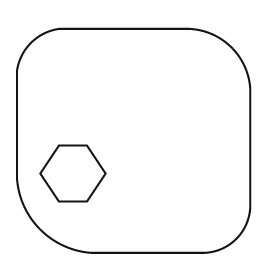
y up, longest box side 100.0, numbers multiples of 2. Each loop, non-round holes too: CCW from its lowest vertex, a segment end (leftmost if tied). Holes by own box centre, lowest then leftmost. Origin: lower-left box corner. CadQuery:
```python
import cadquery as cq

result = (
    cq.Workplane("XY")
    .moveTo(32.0, 0.0)
    .lineTo(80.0, 0.0)
    .threePointArc((94.0, 6.0), (100.0, 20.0))
    .lineTo(100.0, 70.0)
    .threePointArc((92.0, 88.0), (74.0, 96.0))
    .lineTo(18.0, 96.0)
    .threePointArc((6.0, 90.0), (0.0, 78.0))
    .lineTo(0.0, 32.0)
    .threePointArc((10.0, 10.0), (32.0, 0.0))
    .close()
    .moveTo(18.0, 22.0)
    .lineTo(30.0, 22.0)
    .lineTo(38.0, 34.0)
    .lineTo(30.0, 46.0)
    .lineTo(18.0, 46.0)
    .lineTo(10.0, 34.0)
    .close()
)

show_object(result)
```